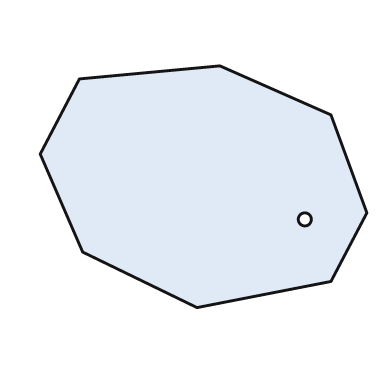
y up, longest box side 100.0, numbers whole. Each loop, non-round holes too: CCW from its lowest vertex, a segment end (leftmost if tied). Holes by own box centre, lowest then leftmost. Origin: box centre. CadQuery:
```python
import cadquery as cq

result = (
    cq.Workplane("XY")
    .moveTo(-2.0, -37.0)
    .lineTo(39.0, -29.0)
    .lineTo(50.0, -8.0)
    .lineTo(39.0, 22.0)
    .lineTo(5.0, 37.0)
    .lineTo(-38.0, 33.0)
    .lineTo(-50.0, 10.0)
    .lineTo(-37.0, -20.0)
    .close()
    .moveTo(31.0, -10.0)
    .circle(2.0)
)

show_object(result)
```